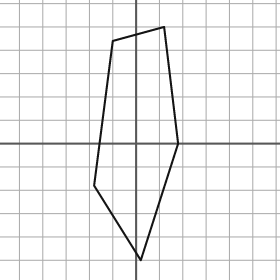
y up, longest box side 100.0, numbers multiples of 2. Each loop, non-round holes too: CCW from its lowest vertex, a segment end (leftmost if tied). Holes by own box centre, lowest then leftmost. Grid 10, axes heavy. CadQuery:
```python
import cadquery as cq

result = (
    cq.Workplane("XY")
    .moveTo(2.0, -50.0)
    .lineTo(18.0, 0.0)
    .lineTo(12.0, 50.0)
    .lineTo(-10.0, 44.0)
    .lineTo(-18.0, -18.0)
    .close()
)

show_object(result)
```